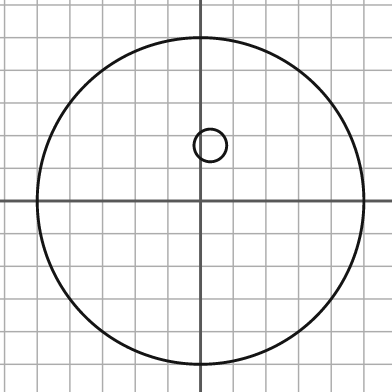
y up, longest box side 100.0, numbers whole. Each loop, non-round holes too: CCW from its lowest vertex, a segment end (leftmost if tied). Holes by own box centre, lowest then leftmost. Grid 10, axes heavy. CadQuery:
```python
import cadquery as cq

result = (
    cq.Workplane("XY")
    .moveTo(0.0, 0.0)
    .circle(50.0)
    .moveTo(3.0, 17.0)
    .circle(5.0)
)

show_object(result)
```